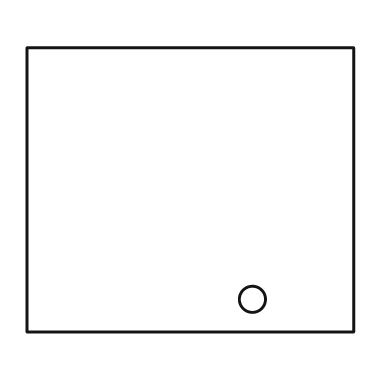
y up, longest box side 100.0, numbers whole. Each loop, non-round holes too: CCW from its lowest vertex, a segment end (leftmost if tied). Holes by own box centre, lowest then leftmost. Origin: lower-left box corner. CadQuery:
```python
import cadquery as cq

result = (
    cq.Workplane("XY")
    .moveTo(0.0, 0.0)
    .lineTo(100.0, 0.0)
    .lineTo(100.0, 87.0)
    .lineTo(0.0, 87.0)
    .close()
    .moveTo(69.0, 10.0)
    .circle(4.0)
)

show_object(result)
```